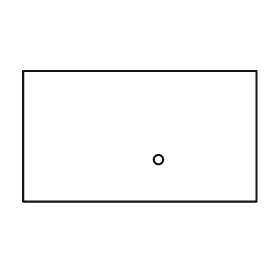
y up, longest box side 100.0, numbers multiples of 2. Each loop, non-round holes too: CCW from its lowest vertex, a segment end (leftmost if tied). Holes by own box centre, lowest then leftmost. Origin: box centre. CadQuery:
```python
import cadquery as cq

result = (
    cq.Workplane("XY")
    .moveTo(-50.0, -28.0)
    .lineTo(50.0, -28.0)
    .lineTo(50.0, 28.0)
    .lineTo(-50.0, 28.0)
    .close()
    .moveTo(8.0, -10.0)
    .circle(2.0)
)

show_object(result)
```